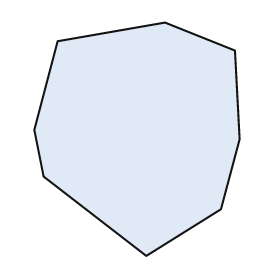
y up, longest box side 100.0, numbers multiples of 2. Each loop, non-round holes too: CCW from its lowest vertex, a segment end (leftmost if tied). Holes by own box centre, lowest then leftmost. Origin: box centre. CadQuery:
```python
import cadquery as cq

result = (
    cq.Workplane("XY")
    .moveTo(4.0, -50.0)
    .lineTo(36.0, -30.0)
    .lineTo(44.0, 0.0)
    .lineTo(42.0, 38.0)
    .lineTo(12.0, 50.0)
    .lineTo(-34.0, 42.0)
    .lineTo(-44.0, 4.0)
    .lineTo(-40.0, -16.0)
    .close()
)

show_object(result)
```